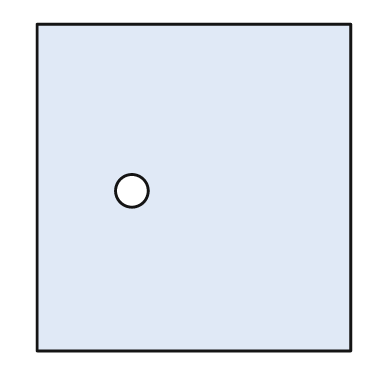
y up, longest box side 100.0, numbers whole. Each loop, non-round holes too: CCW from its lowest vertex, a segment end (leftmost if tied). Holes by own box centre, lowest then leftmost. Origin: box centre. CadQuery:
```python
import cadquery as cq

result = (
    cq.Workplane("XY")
    .moveTo(-48.0, -50.0)
    .lineTo(48.0, -50.0)
    .lineTo(48.0, 50.0)
    .lineTo(-48.0, 50.0)
    .close()
    .moveTo(-19.0, -1.0)
    .circle(5.0)
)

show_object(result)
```